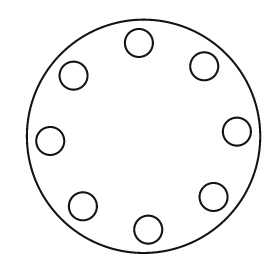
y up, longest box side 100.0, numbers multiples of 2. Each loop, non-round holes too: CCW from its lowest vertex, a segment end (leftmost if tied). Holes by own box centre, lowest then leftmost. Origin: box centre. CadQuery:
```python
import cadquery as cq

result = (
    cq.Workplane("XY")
    .moveTo(0.0, 0.0)
    .circle(50.0)
    .moveTo(2.0, -40.0)
    .circle(6.0)
    .moveTo(-26.0, -30.0)
    .circle(6.0)
    .moveTo(30.0, -26.0)
    .circle(6.0)
    .moveTo(-40.0, -2.0)
    .circle(6.0)
    .moveTo(40.0, 2.0)
    .circle(6.0)
    .moveTo(-30.0, 26.0)
    .circle(6.0)
    .moveTo(26.0, 30.0)
    .circle(6.0)
    .moveTo(-2.0, 40.0)
    .circle(6.0)
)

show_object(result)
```